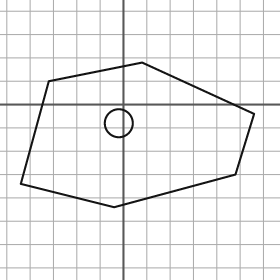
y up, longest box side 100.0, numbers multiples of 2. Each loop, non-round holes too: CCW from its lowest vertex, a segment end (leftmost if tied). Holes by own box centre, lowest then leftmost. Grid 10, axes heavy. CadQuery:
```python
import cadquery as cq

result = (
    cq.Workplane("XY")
    .moveTo(-4.0, -44.0)
    .lineTo(48.0, -30.0)
    .lineTo(56.0, -4.0)
    .lineTo(8.0, 18.0)
    .lineTo(-32.0, 10.0)
    .lineTo(-44.0, -34.0)
    .close()
    .moveTo(-2.0, -8.0)
    .circle(6.0)
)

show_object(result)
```